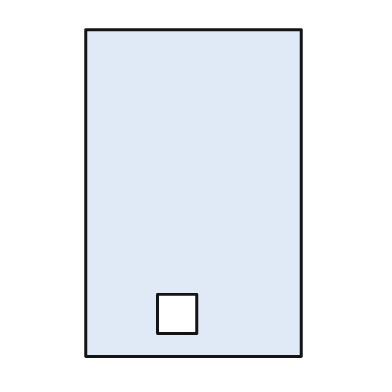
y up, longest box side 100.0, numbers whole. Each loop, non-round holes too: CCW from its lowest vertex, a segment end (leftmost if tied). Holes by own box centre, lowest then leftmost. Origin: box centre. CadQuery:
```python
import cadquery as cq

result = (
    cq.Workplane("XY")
    .moveTo(-33.0, -50.0)
    .lineTo(33.0, -50.0)
    .lineTo(33.0, 50.0)
    .lineTo(-33.0, 50.0)
    .close()
    .moveTo(-11.0, -43.0)
    .lineTo(1.0, -43.0)
    .lineTo(1.0, -31.0)
    .lineTo(-11.0, -31.0)
    .close()
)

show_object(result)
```